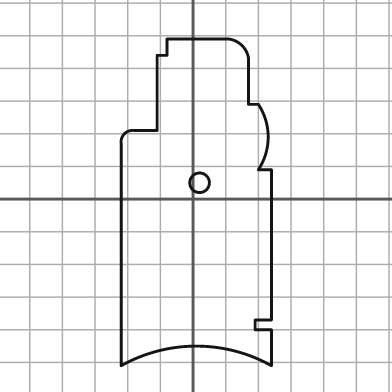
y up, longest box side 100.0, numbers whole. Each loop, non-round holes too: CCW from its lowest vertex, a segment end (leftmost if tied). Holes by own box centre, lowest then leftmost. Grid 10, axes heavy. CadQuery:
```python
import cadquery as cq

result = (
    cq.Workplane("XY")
    .moveTo(-22.0, -51.0)
    .threePointArc((1.0, -45.0), (24.0, -51.0))
    .lineTo(24.0, -40.0)
    .lineTo(19.0, -40.0)
    .lineTo(19.0, -37.0)
    .lineTo(24.0, -37.0)
    .lineTo(24.0, 9.0)
    .lineTo(20.0, 9.0)
    .threePointArc((23.0, 19.0), (20.0, 29.0))
    .lineTo(17.0, 29.0)
    .lineTo(17.0, 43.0)
    .threePointArc((15.0, 47.0), (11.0, 49.0))
    .lineTo(-8.0, 49.0)
    .lineTo(-8.0, 44.0)
    .lineTo(-11.0, 44.0)
    .lineTo(-11.0, 21.0)
    .lineTo(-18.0, 21.0)
    .threePointArc((-21.0, 20.0), (-22.0, 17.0))
    .close()
    .moveTo(2.0, 5.0)
    .circle(3.0)
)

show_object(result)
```